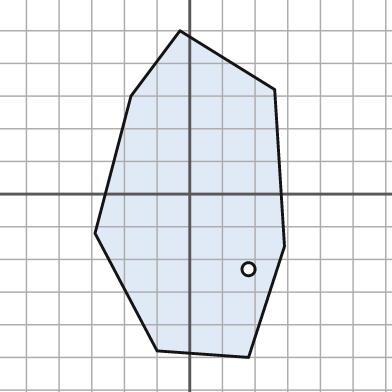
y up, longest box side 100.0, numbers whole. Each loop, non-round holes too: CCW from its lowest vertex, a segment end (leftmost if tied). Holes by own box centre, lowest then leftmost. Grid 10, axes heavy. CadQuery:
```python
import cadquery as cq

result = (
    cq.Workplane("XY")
    .moveTo(18.0, -50.0)
    .lineTo(29.0, -16.0)
    .lineTo(26.0, 32.0)
    .lineTo(-3.0, 50.0)
    .lineTo(-18.0, 30.0)
    .lineTo(-29.0, -12.0)
    .lineTo(-10.0, -48.0)
    .close()
    .moveTo(18.0, -23.0)
    .circle(2.0)
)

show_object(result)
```